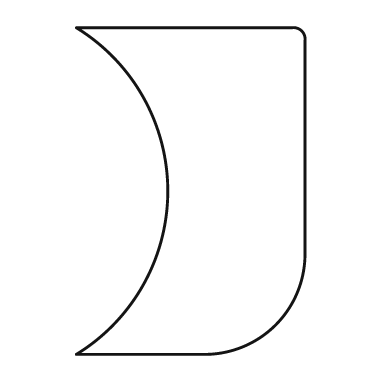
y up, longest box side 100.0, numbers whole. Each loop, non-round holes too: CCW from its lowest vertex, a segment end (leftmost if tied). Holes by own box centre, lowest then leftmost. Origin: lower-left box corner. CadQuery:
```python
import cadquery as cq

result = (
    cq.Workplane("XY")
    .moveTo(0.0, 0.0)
    .lineTo(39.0, 0.0)
    .threePointArc((61.0, 9.0), (70.0, 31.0))
    .lineTo(70.0, 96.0)
    .threePointArc((69.0, 99.0), (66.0, 100.0))
    .lineTo(0.0, 100.0)
    .threePointArc((28.0, 50.0), (0.0, 0.0))
    .close()
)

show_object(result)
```